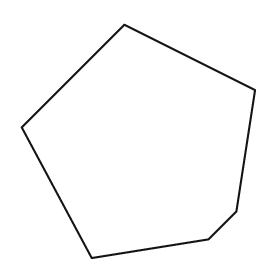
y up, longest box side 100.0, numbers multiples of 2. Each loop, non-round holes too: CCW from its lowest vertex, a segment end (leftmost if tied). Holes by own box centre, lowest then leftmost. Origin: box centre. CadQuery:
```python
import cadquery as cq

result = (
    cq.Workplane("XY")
    .moveTo(-20.0, -50.0)
    .lineTo(30.0, -42.0)
    .lineTo(42.0, -30.0)
    .lineTo(50.0, 22.0)
    .lineTo(-6.0, 50.0)
    .lineTo(-50.0, 6.0)
    .close()
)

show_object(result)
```